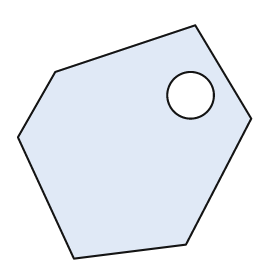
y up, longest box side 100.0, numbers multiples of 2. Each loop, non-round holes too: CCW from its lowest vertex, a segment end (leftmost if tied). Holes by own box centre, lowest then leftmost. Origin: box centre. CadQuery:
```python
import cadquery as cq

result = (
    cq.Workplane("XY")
    .moveTo(-26.0, -50.0)
    .lineTo(22.0, -44.0)
    .lineTo(50.0, 10.0)
    .lineTo(26.0, 50.0)
    .lineTo(-34.0, 30.0)
    .lineTo(-50.0, 2.0)
    .close()
    .moveTo(24.0, 20.0)
    .circle(10.0)
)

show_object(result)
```